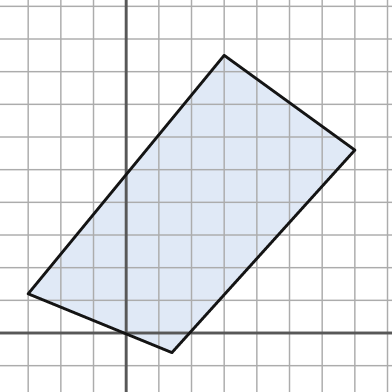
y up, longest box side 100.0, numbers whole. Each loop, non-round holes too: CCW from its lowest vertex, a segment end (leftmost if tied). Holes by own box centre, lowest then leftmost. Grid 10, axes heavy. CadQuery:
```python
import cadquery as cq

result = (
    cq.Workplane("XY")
    .moveTo(14.0, -6.0)
    .lineTo(70.0, 56.0)
    .lineTo(30.0, 85.0)
    .lineTo(-30.0, 12.0)
    .close()
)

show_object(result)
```